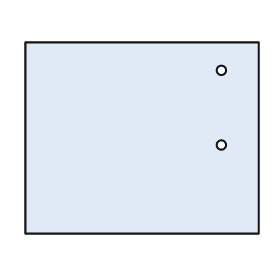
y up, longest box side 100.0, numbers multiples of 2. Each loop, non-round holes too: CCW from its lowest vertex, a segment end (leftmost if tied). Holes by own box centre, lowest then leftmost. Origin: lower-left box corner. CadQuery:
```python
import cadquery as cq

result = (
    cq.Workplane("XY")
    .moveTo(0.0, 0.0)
    .lineTo(100.0, 0.0)
    .lineTo(100.0, 82.0)
    .lineTo(0.0, 82.0)
    .close()
    .moveTo(84.0, 38.0)
    .circle(2.0)
    .moveTo(84.0, 70.0)
    .circle(2.0)
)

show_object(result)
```